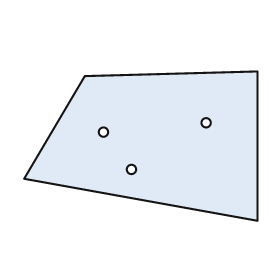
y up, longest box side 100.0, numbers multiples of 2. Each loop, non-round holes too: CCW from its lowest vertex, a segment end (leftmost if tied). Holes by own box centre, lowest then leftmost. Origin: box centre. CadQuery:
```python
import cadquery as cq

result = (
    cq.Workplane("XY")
    .moveTo(50.0, -32.0)
    .lineTo(50.0, 32.0)
    .lineTo(-24.0, 30.0)
    .lineTo(-50.0, -14.0)
    .close()
    .moveTo(-4.0, -10.0)
    .circle(2.0)
    .moveTo(-16.0, 6.0)
    .circle(2.0)
    .moveTo(28.0, 10.0)
    .circle(2.0)
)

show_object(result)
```